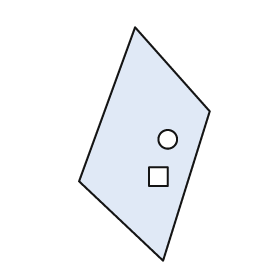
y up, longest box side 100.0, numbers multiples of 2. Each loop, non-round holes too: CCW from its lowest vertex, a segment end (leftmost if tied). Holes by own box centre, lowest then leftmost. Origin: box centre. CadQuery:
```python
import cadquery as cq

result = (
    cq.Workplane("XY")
    .moveTo(8.0, -50.0)
    .lineTo(28.0, 14.0)
    .lineTo(-4.0, 50.0)
    .lineTo(-28.0, -16.0)
    .close()
    .moveTo(2.0, -18.0)
    .lineTo(10.0, -18.0)
    .lineTo(10.0, -10.0)
    .lineTo(2.0, -10.0)
    .close()
    .moveTo(10.0, 2.0)
    .circle(4.0)
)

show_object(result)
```